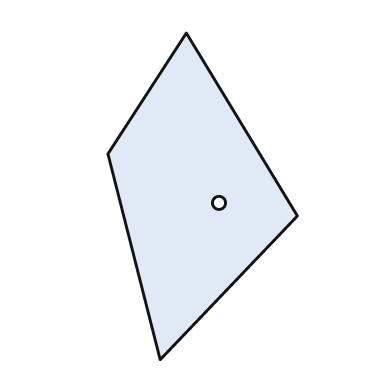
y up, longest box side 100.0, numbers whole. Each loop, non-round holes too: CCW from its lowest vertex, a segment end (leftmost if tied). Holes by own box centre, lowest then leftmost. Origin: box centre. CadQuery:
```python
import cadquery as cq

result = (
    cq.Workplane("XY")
    .moveTo(-13.0, -50.0)
    .lineTo(29.0, -6.0)
    .lineTo(-5.0, 50.0)
    .lineTo(-29.0, 13.0)
    .close()
    .moveTo(5.0, -2.0)
    .circle(2.0)
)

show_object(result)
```